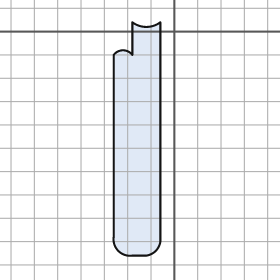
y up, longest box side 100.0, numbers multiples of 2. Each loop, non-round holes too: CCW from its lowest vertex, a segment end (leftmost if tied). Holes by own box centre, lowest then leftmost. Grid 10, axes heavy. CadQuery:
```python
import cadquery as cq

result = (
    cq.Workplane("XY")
    .moveTo(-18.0, -96.0)
    .lineTo(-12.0, -96.0)
    .threePointArc((-8.0, -94.0), (-6.0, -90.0))
    .lineTo(-6.0, 4.0)
    .threePointArc((-12.0, 2.0), (-18.0, 4.0))
    .lineTo(-18.0, -10.0)
    .threePointArc((-22.0, -8.0), (-26.0, -10.0))
    .lineTo(-26.0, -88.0)
    .threePointArc((-24.0, -94.0), (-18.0, -96.0))
    .close()
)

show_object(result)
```